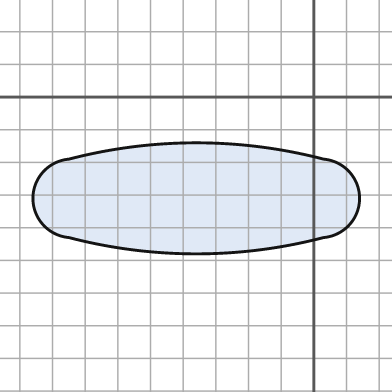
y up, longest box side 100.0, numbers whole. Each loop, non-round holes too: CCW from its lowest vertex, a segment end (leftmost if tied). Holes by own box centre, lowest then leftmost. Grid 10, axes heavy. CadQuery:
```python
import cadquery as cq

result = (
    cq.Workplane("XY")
    .moveTo(-75.0, -43.0)
    .threePointArc((-36.0, -48.0), (3.0, -43.0))
    .threePointArc((14.0, -31.0), (3.0, -19.0))
    .threePointArc((-36.0, -14.0), (-75.0, -19.0))
    .threePointArc((-86.0, -31.0), (-75.0, -43.0))
    .close()
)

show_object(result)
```